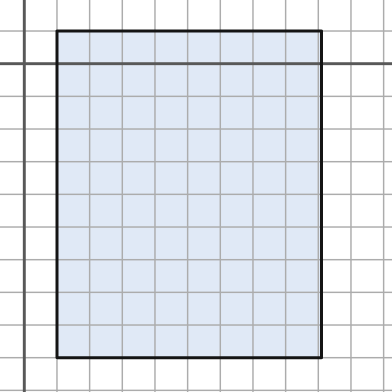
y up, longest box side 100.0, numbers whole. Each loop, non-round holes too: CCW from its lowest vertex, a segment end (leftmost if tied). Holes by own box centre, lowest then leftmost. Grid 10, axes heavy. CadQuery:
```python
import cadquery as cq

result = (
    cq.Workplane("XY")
    .moveTo(10.0, -90.0)
    .lineTo(91.0, -90.0)
    .lineTo(91.0, 10.0)
    .lineTo(10.0, 10.0)
    .close()
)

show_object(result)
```